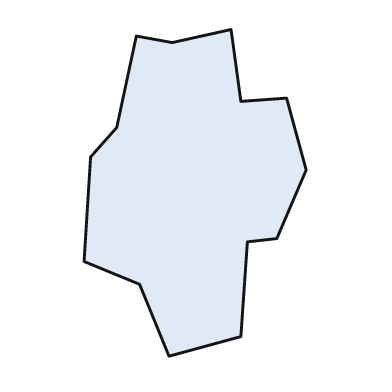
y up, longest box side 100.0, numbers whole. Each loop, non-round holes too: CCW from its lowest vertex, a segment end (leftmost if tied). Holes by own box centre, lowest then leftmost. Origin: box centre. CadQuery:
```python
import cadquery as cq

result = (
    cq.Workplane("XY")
    .moveTo(-8.0, -50.0)
    .lineTo(14.0, -44.0)
    .lineTo(16.0, -15.0)
    .lineTo(25.0, -14.0)
    .lineTo(34.0, 7.0)
    .lineTo(28.0, 29.0)
    .lineTo(14.0, 28.0)
    .lineTo(11.0, 50.0)
    .lineTo(-7.0, 46.0)
    .lineTo(-18.0, 48.0)
    .lineTo(-24.0, 20.0)
    .lineTo(-32.0, 11.0)
    .lineTo(-34.0, -21.0)
    .lineTo(-17.0, -28.0)
    .close()
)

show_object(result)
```